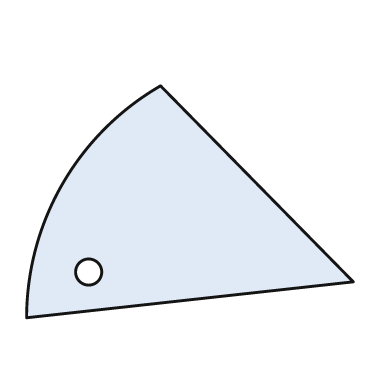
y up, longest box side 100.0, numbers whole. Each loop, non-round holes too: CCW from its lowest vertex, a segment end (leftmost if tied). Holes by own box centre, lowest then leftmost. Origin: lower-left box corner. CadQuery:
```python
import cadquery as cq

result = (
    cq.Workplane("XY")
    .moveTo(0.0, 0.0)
    .lineTo(100.0, 11.0)
    .lineTo(41.0, 71.0)
    .threePointArc((11.0, 41.0), (0.0, 0.0))
    .close()
    .moveTo(19.0, 14.0)
    .circle(4.0)
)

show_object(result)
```